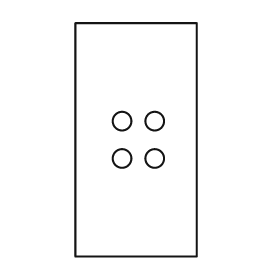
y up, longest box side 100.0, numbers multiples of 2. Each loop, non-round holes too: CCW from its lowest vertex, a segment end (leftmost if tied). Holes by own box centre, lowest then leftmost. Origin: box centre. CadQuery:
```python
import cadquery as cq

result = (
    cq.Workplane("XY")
    .moveTo(-26.0, -50.0)
    .lineTo(26.0, -50.0)
    .lineTo(26.0, 50.0)
    .lineTo(-26.0, 50.0)
    .close()
    .moveTo(-6.0, -8.0)
    .circle(4.0)
    .moveTo(8.0, -8.0)
    .circle(4.0)
    .moveTo(-6.0, 8.0)
    .circle(4.0)
    .moveTo(8.0, 8.0)
    .circle(4.0)
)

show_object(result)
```